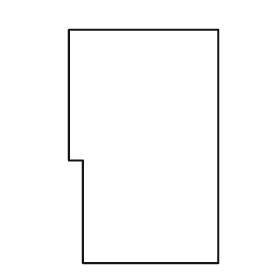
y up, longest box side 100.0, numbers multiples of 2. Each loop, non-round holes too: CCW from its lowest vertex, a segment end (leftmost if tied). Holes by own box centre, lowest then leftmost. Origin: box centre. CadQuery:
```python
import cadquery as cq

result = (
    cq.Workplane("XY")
    .moveTo(-26.0, -50.0)
    .lineTo(32.0, -50.0)
    .lineTo(32.0, 50.0)
    .lineTo(-32.0, 50.0)
    .lineTo(-32.0, -6.0)
    .lineTo(-26.0, -6.0)
    .close()
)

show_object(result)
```